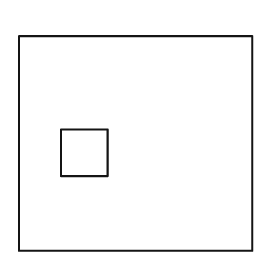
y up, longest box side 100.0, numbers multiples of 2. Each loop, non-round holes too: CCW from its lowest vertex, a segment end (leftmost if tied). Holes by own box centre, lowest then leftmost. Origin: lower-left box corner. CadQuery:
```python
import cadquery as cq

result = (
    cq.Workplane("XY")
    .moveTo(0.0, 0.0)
    .lineTo(100.0, 0.0)
    .lineTo(100.0, 92.0)
    .lineTo(0.0, 92.0)
    .close()
    .moveTo(18.0, 32.0)
    .lineTo(38.0, 32.0)
    .lineTo(38.0, 52.0)
    .lineTo(18.0, 52.0)
    .close()
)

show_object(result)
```